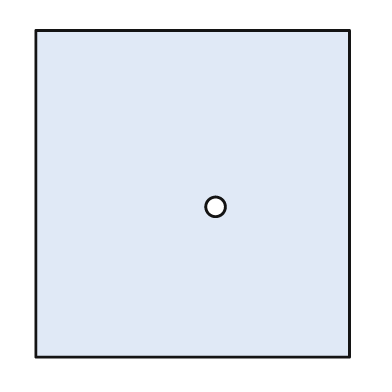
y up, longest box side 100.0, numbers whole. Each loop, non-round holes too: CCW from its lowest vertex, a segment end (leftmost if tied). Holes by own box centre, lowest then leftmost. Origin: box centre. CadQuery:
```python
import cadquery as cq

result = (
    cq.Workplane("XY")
    .moveTo(-48.0, -50.0)
    .lineTo(48.0, -50.0)
    .lineTo(48.0, 50.0)
    .lineTo(-48.0, 50.0)
    .close()
    .moveTo(7.0, -4.0)
    .circle(3.0)
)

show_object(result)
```